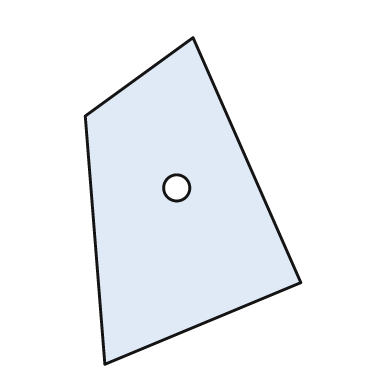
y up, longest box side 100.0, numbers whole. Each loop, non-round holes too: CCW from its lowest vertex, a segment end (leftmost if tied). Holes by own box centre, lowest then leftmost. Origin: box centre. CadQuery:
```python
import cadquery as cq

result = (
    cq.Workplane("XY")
    .moveTo(-27.0, -50.0)
    .lineTo(33.0, -25.0)
    .lineTo(0.0, 50.0)
    .lineTo(-33.0, 26.0)
    .close()
    .moveTo(-5.0, 4.0)
    .circle(4.0)
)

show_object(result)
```